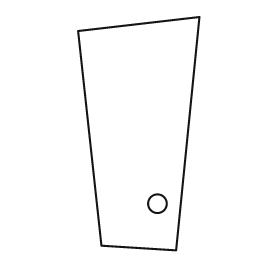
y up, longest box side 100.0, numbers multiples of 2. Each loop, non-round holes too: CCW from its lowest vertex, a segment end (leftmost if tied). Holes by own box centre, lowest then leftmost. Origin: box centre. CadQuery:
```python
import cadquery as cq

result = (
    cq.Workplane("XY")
    .moveTo(16.0, -50.0)
    .lineTo(26.0, 50.0)
    .lineTo(-26.0, 44.0)
    .lineTo(-16.0, -48.0)
    .close()
    .moveTo(8.0, -30.0)
    .circle(4.0)
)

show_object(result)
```